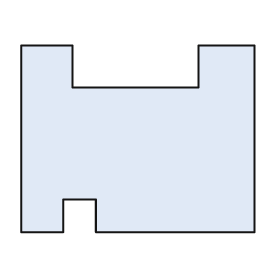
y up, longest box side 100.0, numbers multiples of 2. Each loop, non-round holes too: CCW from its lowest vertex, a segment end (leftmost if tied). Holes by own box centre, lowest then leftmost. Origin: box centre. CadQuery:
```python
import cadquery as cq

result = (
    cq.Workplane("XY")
    .moveTo(-50.0, -40.0)
    .lineTo(-32.0, -40.0)
    .lineTo(-32.0, -26.0)
    .lineTo(-18.0, -26.0)
    .lineTo(-18.0, -40.0)
    .lineTo(50.0, -40.0)
    .lineTo(50.0, 40.0)
    .lineTo(26.0, 40.0)
    .lineTo(26.0, 22.0)
    .lineTo(-28.0, 22.0)
    .lineTo(-28.0, 40.0)
    .lineTo(-50.0, 40.0)
    .close()
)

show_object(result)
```